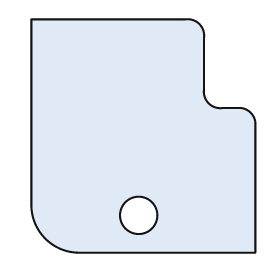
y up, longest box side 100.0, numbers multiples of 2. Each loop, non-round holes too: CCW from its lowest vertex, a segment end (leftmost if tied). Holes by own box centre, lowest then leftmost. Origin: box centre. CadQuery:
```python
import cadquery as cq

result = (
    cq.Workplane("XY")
    .moveTo(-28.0, -50.0)
    .lineTo(48.0, -50.0)
    .lineTo(48.0, 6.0)
    .threePointArc((46.0, 10.0), (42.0, 12.0))
    .lineTo(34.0, 12.0)
    .threePointArc((28.0, 14.0), (26.0, 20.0))
    .lineTo(26.0, 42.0)
    .threePointArc((24.0, 48.0), (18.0, 50.0))
    .lineTo(-48.0, 50.0)
    .lineTo(-48.0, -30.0)
    .threePointArc((-42.0, -44.0), (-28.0, -50.0))
    .close()
    .moveTo(-2.0, -34.0)
    .circle(8.0)
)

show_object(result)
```